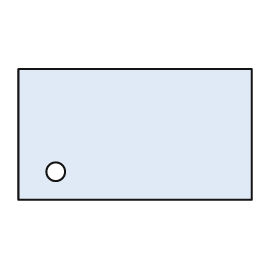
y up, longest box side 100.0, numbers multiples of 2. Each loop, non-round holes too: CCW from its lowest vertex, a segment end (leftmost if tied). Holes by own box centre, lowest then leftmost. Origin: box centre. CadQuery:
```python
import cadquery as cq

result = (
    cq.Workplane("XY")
    .moveTo(-50.0, -28.0)
    .lineTo(50.0, -28.0)
    .lineTo(50.0, 28.0)
    .lineTo(-50.0, 28.0)
    .close()
    .moveTo(-34.0, -16.0)
    .circle(4.0)
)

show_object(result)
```